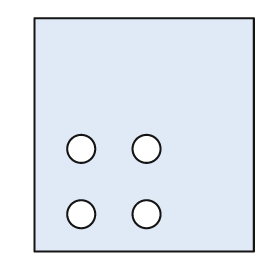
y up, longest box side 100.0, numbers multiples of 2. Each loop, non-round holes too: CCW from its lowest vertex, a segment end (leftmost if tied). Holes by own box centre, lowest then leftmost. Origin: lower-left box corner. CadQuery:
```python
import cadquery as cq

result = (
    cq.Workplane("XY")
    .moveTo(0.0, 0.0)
    .lineTo(94.0, 0.0)
    .lineTo(94.0, 100.0)
    .lineTo(0.0, 100.0)
    .close()
    .moveTo(20.0, 16.0)
    .circle(6.0)
    .moveTo(48.0, 16.0)
    .circle(6.0)
    .moveTo(20.0, 44.0)
    .circle(6.0)
    .moveTo(48.0, 44.0)
    .circle(6.0)
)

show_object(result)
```